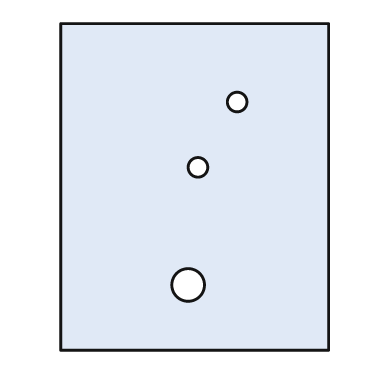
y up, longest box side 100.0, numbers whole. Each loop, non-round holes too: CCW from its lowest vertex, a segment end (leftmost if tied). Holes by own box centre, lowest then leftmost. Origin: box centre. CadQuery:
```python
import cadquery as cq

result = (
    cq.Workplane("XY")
    .moveTo(-41.0, -50.0)
    .lineTo(41.0, -50.0)
    .lineTo(41.0, 50.0)
    .lineTo(-41.0, 50.0)
    .close()
    .moveTo(-2.0, -30.0)
    .circle(5.0)
    .moveTo(1.0, 6.0)
    .circle(3.0)
    .moveTo(13.0, 26.0)
    .circle(3.0)
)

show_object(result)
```